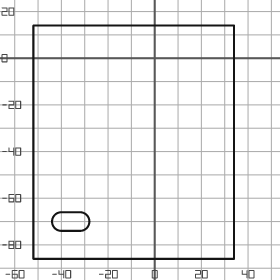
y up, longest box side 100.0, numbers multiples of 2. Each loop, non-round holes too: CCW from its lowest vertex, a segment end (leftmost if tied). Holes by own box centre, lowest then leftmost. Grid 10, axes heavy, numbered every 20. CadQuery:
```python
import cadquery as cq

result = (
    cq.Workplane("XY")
    .moveTo(-52.0, -86.0)
    .lineTo(34.0, -86.0)
    .lineTo(34.0, 14.0)
    .lineTo(-52.0, 14.0)
    .close()
    .moveTo(-40.0, -74.0)
    .lineTo(-32.0, -74.0)
    .threePointArc((-28.0, -70.0), (-32.0, -66.0))
    .lineTo(-40.0, -66.0)
    .threePointArc((-44.0, -70.0), (-40.0, -74.0))
    .close()
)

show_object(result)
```